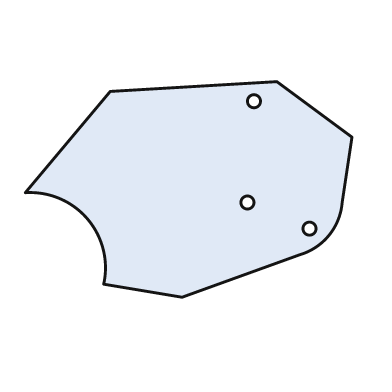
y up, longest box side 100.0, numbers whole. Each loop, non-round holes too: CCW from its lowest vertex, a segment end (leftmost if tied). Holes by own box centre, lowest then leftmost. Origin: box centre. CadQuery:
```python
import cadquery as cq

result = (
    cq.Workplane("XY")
    .moveTo(-2.0, -33.0)
    .lineTo(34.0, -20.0)
    .threePointArc((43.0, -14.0), (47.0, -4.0))
    .lineTo(50.0, 16.0)
    .lineTo(27.0, 33.0)
    .lineTo(-24.0, 30.0)
    .lineTo(-50.0, -1.0)
    .threePointArc((-31.0, -9.0), (-26.0, -29.0))
    .close()
    .moveTo(37.0, -12.0)
    .circle(2.0)
    .moveTo(18.0, -4.0)
    .circle(2.0)
    .moveTo(20.0, 27.0)
    .circle(2.0)
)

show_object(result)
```